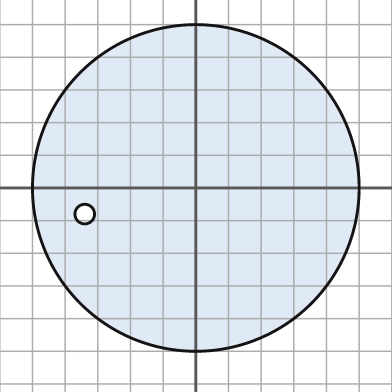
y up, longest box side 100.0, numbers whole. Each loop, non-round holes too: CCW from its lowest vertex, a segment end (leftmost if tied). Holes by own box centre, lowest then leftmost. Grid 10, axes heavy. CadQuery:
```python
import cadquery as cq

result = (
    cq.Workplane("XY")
    .moveTo(0.0, 0.0)
    .circle(50.0)
    .moveTo(-34.0, -8.0)
    .circle(3.0)
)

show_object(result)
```